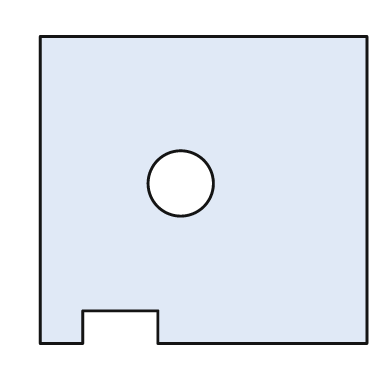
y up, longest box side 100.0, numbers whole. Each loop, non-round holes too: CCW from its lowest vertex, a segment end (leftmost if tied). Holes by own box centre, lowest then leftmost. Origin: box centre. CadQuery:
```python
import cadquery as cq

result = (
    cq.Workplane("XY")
    .moveTo(-50.0, -47.0)
    .lineTo(-37.0, -47.0)
    .lineTo(-37.0, -37.0)
    .lineTo(-14.0, -37.0)
    .lineTo(-14.0, -47.0)
    .lineTo(50.0, -47.0)
    .lineTo(50.0, 47.0)
    .lineTo(-50.0, 47.0)
    .close()
    .moveTo(-7.0, 2.0)
    .circle(10.0)
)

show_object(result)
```